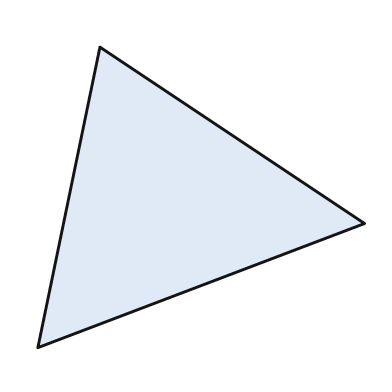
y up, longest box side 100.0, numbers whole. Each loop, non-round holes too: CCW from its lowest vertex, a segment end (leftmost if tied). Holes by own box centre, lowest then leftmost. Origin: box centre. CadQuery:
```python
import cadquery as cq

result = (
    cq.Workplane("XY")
    .moveTo(-50.0, -46.0)
    .lineTo(50.0, -8.0)
    .lineTo(-31.0, 46.0)
    .close()
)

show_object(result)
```